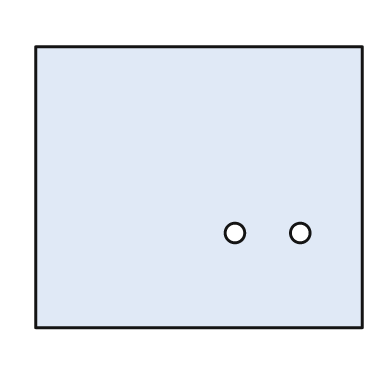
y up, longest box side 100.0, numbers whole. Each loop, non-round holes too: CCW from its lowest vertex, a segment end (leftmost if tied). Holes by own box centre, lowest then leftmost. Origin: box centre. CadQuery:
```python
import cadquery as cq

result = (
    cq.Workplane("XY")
    .moveTo(-50.0, -43.0)
    .lineTo(50.0, -43.0)
    .lineTo(50.0, 43.0)
    .lineTo(-50.0, 43.0)
    .close()
    .moveTo(11.0, -14.0)
    .circle(3.0)
    .moveTo(31.0, -14.0)
    .circle(3.0)
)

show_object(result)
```